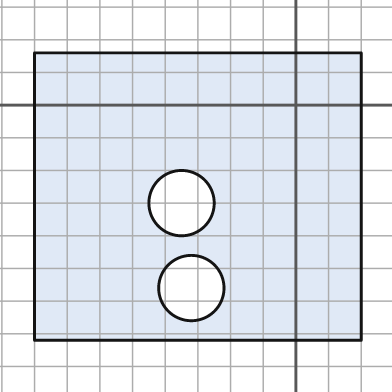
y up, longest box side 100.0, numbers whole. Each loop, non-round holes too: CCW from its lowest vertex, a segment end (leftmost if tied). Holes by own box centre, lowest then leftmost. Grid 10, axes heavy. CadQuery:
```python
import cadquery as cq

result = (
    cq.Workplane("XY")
    .moveTo(-80.0, -72.0)
    .lineTo(20.0, -72.0)
    .lineTo(20.0, 16.0)
    .lineTo(-80.0, 16.0)
    .close()
    .moveTo(-32.0, -56.0)
    .circle(10.0)
    .moveTo(-35.0, -30.0)
    .circle(10.0)
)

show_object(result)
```